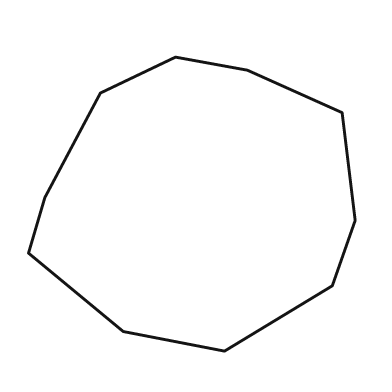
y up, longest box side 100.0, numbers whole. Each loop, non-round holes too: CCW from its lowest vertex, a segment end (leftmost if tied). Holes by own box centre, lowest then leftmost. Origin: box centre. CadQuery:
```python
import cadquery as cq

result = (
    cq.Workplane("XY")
    .moveTo(10.0, -45.0)
    .lineTo(43.0, -25.0)
    .lineTo(50.0, -5.0)
    .lineTo(46.0, 28.0)
    .lineTo(17.0, 41.0)
    .lineTo(-5.0, 45.0)
    .lineTo(-28.0, 34.0)
    .lineTo(-45.0, 2.0)
    .lineTo(-50.0, -15.0)
    .lineTo(-21.0, -39.0)
    .close()
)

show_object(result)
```